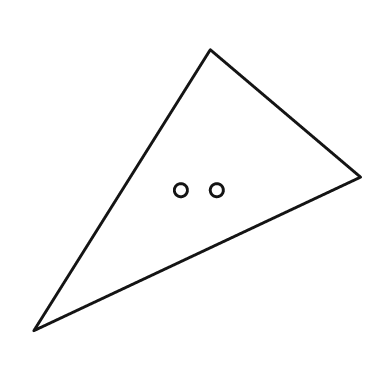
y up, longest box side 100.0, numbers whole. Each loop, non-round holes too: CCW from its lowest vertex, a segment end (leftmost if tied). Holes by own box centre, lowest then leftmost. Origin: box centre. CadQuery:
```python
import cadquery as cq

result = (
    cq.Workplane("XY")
    .moveTo(-50.0, -43.0)
    .lineTo(50.0, 4.0)
    .lineTo(4.0, 43.0)
    .close()
    .moveTo(-5.0, 0.0)
    .circle(2.0)
    .moveTo(6.0, 0.0)
    .circle(2.0)
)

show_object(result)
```